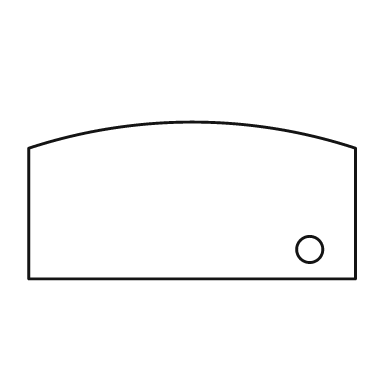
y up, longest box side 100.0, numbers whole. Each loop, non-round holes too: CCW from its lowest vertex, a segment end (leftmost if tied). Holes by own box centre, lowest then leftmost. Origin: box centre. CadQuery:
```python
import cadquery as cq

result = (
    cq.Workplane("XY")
    .moveTo(-50.0, -24.0)
    .lineTo(50.0, -24.0)
    .lineTo(50.0, 16.0)
    .threePointArc((0.0, 24.0), (-50.0, 16.0))
    .close()
    .moveTo(36.0, -15.0)
    .circle(4.0)
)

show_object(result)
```